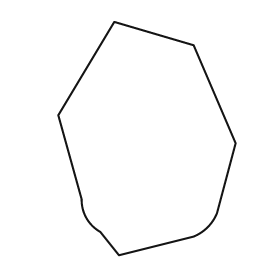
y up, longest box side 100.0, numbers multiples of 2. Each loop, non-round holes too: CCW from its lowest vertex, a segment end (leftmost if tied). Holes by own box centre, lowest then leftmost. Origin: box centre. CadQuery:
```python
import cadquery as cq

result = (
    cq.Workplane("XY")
    .moveTo(-12.0, -50.0)
    .lineTo(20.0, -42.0)
    .threePointArc((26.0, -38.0), (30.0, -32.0))
    .lineTo(38.0, -2.0)
    .lineTo(20.0, 40.0)
    .lineTo(-14.0, 50.0)
    .lineTo(-38.0, 10.0)
    .lineTo(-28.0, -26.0)
    .threePointArc((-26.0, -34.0), (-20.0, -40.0))
    .close()
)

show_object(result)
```